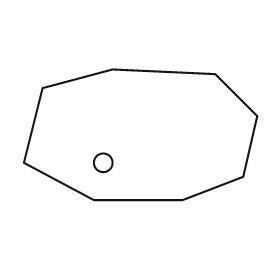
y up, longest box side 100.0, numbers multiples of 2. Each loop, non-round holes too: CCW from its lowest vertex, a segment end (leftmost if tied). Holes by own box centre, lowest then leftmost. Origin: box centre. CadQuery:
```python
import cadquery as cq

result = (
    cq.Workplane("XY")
    .moveTo(-20.0, -28.0)
    .lineTo(18.0, -28.0)
    .lineTo(44.0, -18.0)
    .lineTo(50.0, 8.0)
    .lineTo(32.0, 26.0)
    .lineTo(-12.0, 28.0)
    .lineTo(-42.0, 20.0)
    .lineTo(-50.0, -12.0)
    .close()
    .moveTo(-16.0, -12.0)
    .circle(4.0)
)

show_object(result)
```